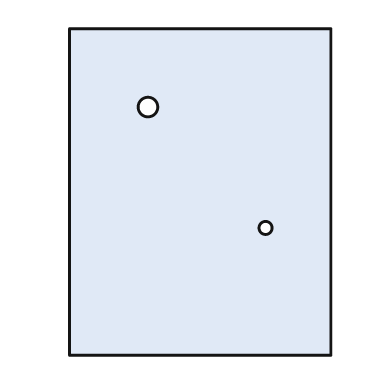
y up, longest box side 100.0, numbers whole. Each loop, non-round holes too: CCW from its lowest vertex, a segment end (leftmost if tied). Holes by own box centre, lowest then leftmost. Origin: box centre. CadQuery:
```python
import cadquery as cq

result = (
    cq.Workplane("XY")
    .moveTo(-40.0, -50.0)
    .lineTo(40.0, -50.0)
    .lineTo(40.0, 50.0)
    .lineTo(-40.0, 50.0)
    .close()
    .moveTo(20.0, -11.0)
    .circle(2.0)
    .moveTo(-16.0, 26.0)
    .circle(3.0)
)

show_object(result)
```